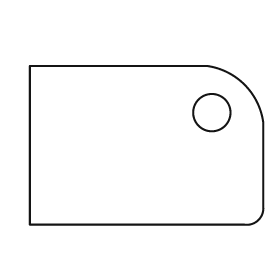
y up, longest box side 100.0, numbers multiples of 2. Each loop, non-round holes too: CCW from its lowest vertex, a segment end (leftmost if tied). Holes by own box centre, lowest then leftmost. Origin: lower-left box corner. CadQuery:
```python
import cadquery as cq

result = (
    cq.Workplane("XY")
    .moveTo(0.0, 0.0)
    .lineTo(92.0, 0.0)
    .threePointArc((98.0, 2.0), (100.0, 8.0))
    .lineTo(100.0, 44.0)
    .threePointArc((92.0, 60.0), (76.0, 68.0))
    .lineTo(0.0, 68.0)
    .close()
    .moveTo(78.0, 48.0)
    .circle(8.0)
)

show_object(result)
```